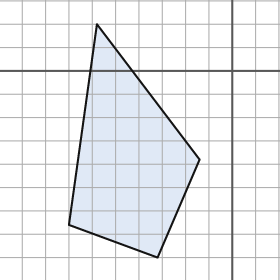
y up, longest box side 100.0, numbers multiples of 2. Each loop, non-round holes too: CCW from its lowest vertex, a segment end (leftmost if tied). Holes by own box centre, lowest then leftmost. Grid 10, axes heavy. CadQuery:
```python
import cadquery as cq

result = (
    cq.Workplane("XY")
    .moveTo(-32.0, -80.0)
    .lineTo(-14.0, -38.0)
    .lineTo(-58.0, 20.0)
    .lineTo(-70.0, -66.0)
    .close()
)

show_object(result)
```